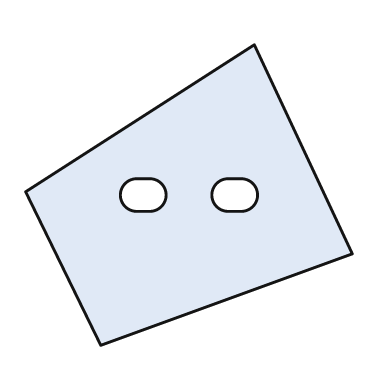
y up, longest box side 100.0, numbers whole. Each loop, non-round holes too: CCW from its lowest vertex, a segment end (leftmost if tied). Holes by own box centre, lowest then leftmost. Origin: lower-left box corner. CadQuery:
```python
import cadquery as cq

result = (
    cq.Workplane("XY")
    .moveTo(23.0, 0.0)
    .lineTo(100.0, 28.0)
    .lineTo(70.0, 92.0)
    .lineTo(0.0, 47.0)
    .close()
    .moveTo(34.0, 41.0)
    .lineTo(38.0, 41.0)
    .threePointArc((43.0, 46.0), (38.0, 51.0))
    .lineTo(34.0, 51.0)
    .threePointArc((29.0, 46.0), (34.0, 41.0))
    .close()
    .moveTo(62.0, 41.0)
    .lineTo(66.0, 41.0)
    .threePointArc((71.0, 46.0), (66.0, 51.0))
    .lineTo(62.0, 51.0)
    .threePointArc((57.0, 46.0), (62.0, 41.0))
    .close()
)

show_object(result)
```